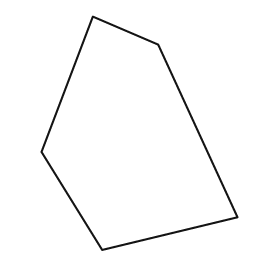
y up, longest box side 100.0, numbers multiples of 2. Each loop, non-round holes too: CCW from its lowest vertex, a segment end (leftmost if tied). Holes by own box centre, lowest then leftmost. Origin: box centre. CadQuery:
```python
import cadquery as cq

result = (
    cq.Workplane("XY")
    .moveTo(-16.0, -50.0)
    .lineTo(42.0, -36.0)
    .lineTo(8.0, 38.0)
    .lineTo(-20.0, 50.0)
    .lineTo(-42.0, -8.0)
    .close()
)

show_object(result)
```